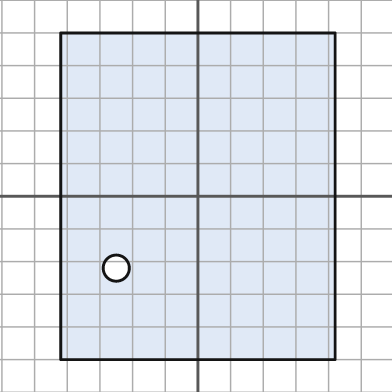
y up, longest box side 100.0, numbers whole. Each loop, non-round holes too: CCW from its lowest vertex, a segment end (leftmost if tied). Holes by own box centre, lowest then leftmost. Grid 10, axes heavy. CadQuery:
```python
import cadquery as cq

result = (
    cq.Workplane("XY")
    .moveTo(-42.0, -50.0)
    .lineTo(42.0, -50.0)
    .lineTo(42.0, 50.0)
    .lineTo(-42.0, 50.0)
    .close()
    .moveTo(-25.0, -22.0)
    .circle(4.0)
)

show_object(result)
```